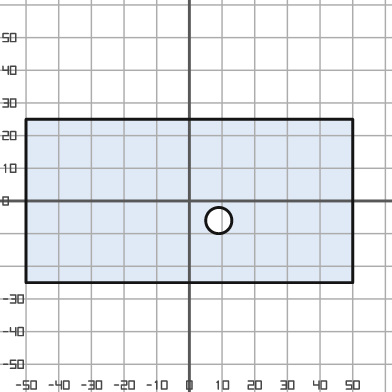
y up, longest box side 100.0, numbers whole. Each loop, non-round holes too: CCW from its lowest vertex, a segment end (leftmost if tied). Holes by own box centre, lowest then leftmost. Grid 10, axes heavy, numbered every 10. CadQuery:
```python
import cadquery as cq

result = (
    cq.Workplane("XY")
    .moveTo(-50.0, -25.0)
    .lineTo(50.0, -25.0)
    .lineTo(50.0, 25.0)
    .lineTo(-50.0, 25.0)
    .close()
    .moveTo(9.0, -6.0)
    .circle(4.0)
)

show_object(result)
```